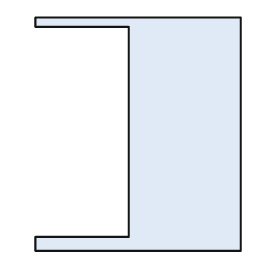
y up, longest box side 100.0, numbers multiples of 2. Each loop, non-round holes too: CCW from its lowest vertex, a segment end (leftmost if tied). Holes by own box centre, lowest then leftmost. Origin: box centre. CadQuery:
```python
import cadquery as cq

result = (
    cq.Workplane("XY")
    .moveTo(-44.0, -50.0)
    .lineTo(44.0, -50.0)
    .lineTo(44.0, 50.0)
    .lineTo(-44.0, 50.0)
    .lineTo(-44.0, 46.0)
    .lineTo(-4.0, 46.0)
    .lineTo(-4.0, -44.0)
    .lineTo(-44.0, -44.0)
    .close()
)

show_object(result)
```